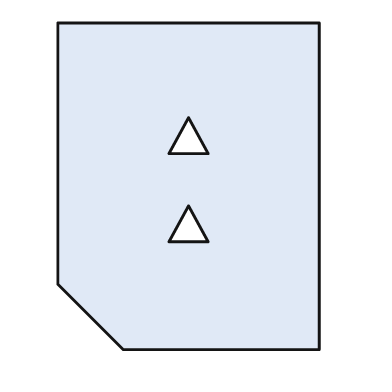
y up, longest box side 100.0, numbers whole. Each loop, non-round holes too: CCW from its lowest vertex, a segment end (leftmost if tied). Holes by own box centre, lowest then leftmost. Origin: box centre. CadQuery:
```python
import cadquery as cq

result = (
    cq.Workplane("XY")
    .moveTo(-20.0, -50.0)
    .lineTo(40.0, -50.0)
    .lineTo(40.0, 50.0)
    .lineTo(-40.0, 50.0)
    .lineTo(-40.0, -30.0)
    .close()
    .moveTo(-6.0, -17.0)
    .lineTo(6.0, -17.0)
    .lineTo(0.0, -6.0)
    .close()
    .moveTo(-6.0, 10.0)
    .lineTo(6.0, 10.0)
    .lineTo(0.0, 21.0)
    .close()
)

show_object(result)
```